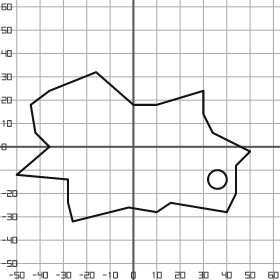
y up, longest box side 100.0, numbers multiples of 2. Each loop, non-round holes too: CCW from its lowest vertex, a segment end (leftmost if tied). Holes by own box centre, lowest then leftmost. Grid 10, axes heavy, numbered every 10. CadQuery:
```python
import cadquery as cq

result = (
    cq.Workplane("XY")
    .moveTo(-26.0, -32.0)
    .lineTo(-2.0, -26.0)
    .lineTo(10.0, -28.0)
    .lineTo(16.0, -24.0)
    .lineTo(40.0, -28.0)
    .lineTo(44.0, -20.0)
    .lineTo(44.0, -8.0)
    .lineTo(50.0, -2.0)
    .lineTo(34.0, 6.0)
    .lineTo(30.0, 14.0)
    .lineTo(30.0, 24.0)
    .lineTo(10.0, 18.0)
    .lineTo(0.0, 18.0)
    .lineTo(-16.0, 32.0)
    .lineTo(-36.0, 24.0)
    .lineTo(-44.0, 18.0)
    .lineTo(-42.0, 6.0)
    .lineTo(-36.0, 0.0)
    .lineTo(-50.0, -12.0)
    .lineTo(-28.0, -14.0)
    .lineTo(-28.0, -24.0)
    .close()
    .moveTo(36.0, -14.0)
    .circle(4.0)
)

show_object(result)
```